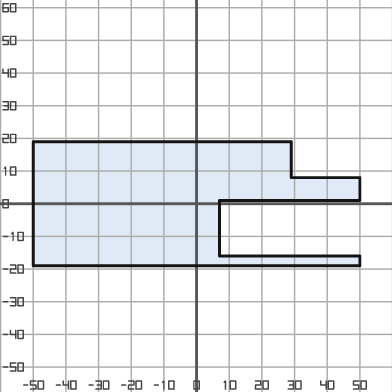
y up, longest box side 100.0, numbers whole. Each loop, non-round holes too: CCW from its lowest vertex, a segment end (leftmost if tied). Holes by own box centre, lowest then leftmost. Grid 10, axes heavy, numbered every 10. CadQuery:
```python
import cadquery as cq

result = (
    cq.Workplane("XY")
    .moveTo(-50.0, -19.0)
    .lineTo(50.0, -19.0)
    .lineTo(50.0, -16.0)
    .lineTo(7.0, -16.0)
    .lineTo(7.0, 1.0)
    .lineTo(50.0, 1.0)
    .lineTo(50.0, 8.0)
    .lineTo(29.0, 8.0)
    .lineTo(29.0, 19.0)
    .lineTo(-50.0, 19.0)
    .close()
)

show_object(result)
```